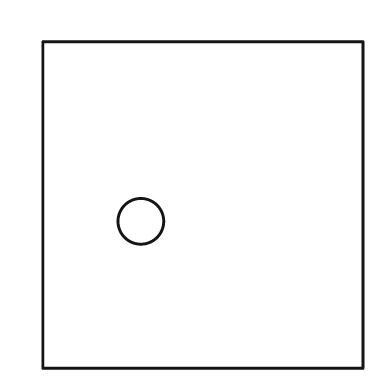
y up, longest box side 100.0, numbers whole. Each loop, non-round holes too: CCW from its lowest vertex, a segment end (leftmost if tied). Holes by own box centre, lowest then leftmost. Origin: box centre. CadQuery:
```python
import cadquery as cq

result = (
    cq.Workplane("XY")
    .moveTo(-49.0, -50.0)
    .lineTo(49.0, -50.0)
    .lineTo(49.0, 50.0)
    .lineTo(-49.0, 50.0)
    .close()
    .moveTo(-19.0, -5.0)
    .circle(7.0)
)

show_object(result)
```